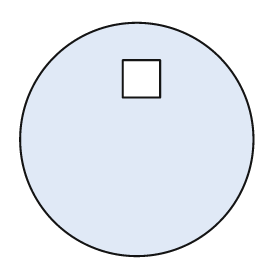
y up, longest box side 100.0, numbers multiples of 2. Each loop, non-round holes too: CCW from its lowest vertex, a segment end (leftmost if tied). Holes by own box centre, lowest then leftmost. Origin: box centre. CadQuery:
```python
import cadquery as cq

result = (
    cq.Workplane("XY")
    .moveTo(0.0, 0.0)
    .circle(50.0)
    .moveTo(-6.0, 18.0)
    .lineTo(10.0, 18.0)
    .lineTo(10.0, 34.0)
    .lineTo(-6.0, 34.0)
    .close()
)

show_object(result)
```